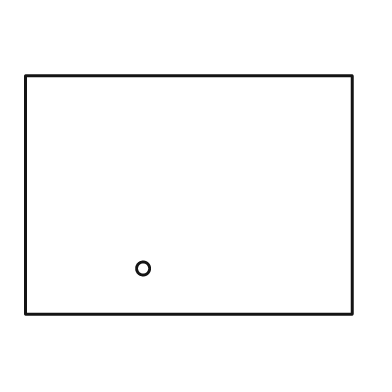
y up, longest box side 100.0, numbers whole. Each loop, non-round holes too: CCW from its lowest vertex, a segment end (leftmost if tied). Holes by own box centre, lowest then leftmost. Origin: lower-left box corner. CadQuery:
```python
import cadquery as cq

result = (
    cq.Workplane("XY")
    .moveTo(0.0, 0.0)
    .lineTo(100.0, 0.0)
    .lineTo(100.0, 73.0)
    .lineTo(0.0, 73.0)
    .close()
    .moveTo(36.0, 14.0)
    .circle(2.0)
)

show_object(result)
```